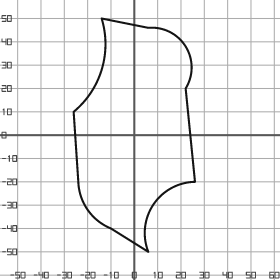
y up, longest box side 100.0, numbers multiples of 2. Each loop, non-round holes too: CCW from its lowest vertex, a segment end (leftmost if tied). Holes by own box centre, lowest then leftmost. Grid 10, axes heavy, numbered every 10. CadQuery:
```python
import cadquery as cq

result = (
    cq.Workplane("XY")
    .moveTo(6.0, -50.0)
    .threePointArc((8.0, -30.0), (26.0, -20.0))
    .lineTo(22.0, 20.0)
    .threePointArc((22.0, 38.0), (6.0, 46.0))
    .lineTo(-14.0, 50.0)
    .threePointArc((-14.0, 28.0), (-26.0, 10.0))
    .lineTo(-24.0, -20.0)
    .threePointArc((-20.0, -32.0), (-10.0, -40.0))
    .close()
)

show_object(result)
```